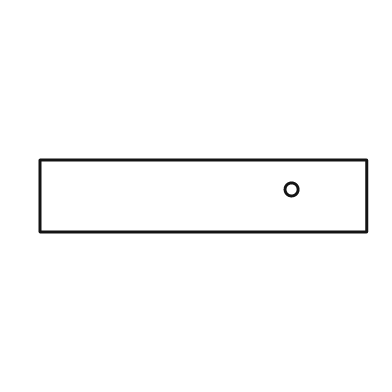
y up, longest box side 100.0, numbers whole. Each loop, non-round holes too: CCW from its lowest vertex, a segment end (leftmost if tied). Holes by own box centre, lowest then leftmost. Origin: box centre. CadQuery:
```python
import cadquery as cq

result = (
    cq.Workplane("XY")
    .moveTo(-50.0, -11.0)
    .lineTo(50.0, -11.0)
    .lineTo(50.0, 11.0)
    .lineTo(-50.0, 11.0)
    .close()
    .moveTo(27.0, 2.0)
    .circle(2.0)
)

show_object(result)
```